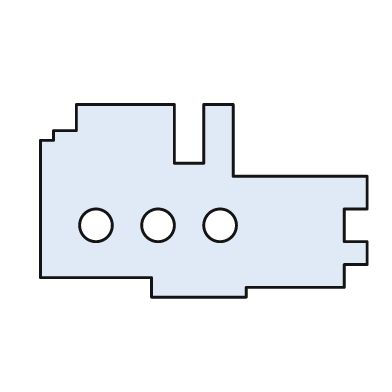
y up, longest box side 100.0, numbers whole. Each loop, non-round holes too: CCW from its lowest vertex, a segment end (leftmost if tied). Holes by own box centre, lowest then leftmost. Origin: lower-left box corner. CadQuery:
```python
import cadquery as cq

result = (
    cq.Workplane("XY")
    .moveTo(34.0, 0.0)
    .lineTo(63.0, 0.0)
    .lineTo(63.0, 3.0)
    .lineTo(93.0, 3.0)
    .lineTo(93.0, 10.0)
    .lineTo(100.0, 10.0)
    .lineTo(100.0, 17.0)
    .lineTo(93.0, 17.0)
    .lineTo(93.0, 27.0)
    .lineTo(100.0, 27.0)
    .lineTo(100.0, 37.0)
    .lineTo(59.0, 37.0)
    .lineTo(59.0, 59.0)
    .lineTo(50.0, 59.0)
    .lineTo(50.0, 41.0)
    .lineTo(41.0, 41.0)
    .lineTo(41.0, 59.0)
    .lineTo(11.0, 59.0)
    .lineTo(11.0, 51.0)
    .lineTo(4.0, 51.0)
    .lineTo(4.0, 48.0)
    .lineTo(0.0, 48.0)
    .lineTo(0.0, 6.0)
    .lineTo(34.0, 6.0)
    .close()
    .moveTo(17.0, 22.0)
    .circle(5.0)
    .moveTo(36.0, 22.0)
    .circle(5.0)
    .moveTo(55.0, 22.0)
    .circle(5.0)
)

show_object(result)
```